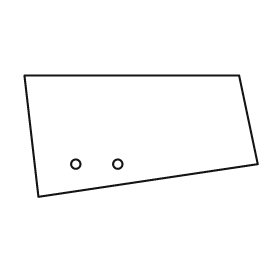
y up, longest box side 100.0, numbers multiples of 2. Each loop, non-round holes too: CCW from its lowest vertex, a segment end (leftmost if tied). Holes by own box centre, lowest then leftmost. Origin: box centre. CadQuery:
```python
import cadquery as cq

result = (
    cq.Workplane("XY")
    .moveTo(-44.0, -26.0)
    .lineTo(50.0, -12.0)
    .lineTo(42.0, 26.0)
    .lineTo(-50.0, 26.0)
    .close()
    .moveTo(-28.0, -12.0)
    .circle(2.0)
    .moveTo(-10.0, -12.0)
    .circle(2.0)
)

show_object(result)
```